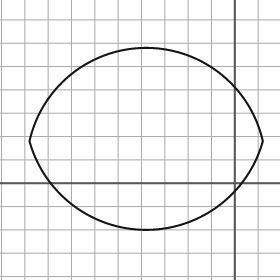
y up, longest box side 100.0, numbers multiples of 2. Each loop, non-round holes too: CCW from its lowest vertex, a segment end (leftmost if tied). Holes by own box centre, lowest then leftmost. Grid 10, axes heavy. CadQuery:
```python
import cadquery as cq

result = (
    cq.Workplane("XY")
    .moveTo(-88.0, 18.0)
    .threePointArc((-38.0, -20.0), (12.0, 18.0))
    .threePointArc((-38.0, 58.0), (-88.0, 18.0))
    .close()
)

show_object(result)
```